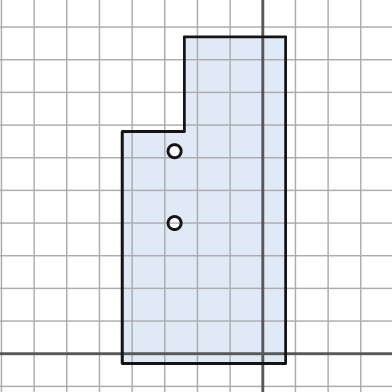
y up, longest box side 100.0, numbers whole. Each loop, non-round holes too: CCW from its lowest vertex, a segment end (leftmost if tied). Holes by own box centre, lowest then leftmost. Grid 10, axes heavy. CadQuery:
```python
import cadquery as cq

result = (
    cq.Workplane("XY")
    .moveTo(-43.0, -3.0)
    .lineTo(7.0, -3.0)
    .lineTo(7.0, 97.0)
    .lineTo(-24.0, 97.0)
    .lineTo(-24.0, 68.0)
    .lineTo(-43.0, 68.0)
    .close()
    .moveTo(-27.0, 40.0)
    .circle(2.0)
    .moveTo(-27.0, 62.0)
    .circle(2.0)
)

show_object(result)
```